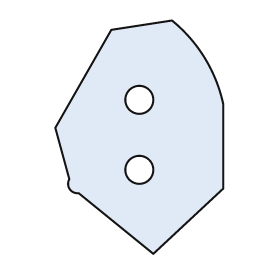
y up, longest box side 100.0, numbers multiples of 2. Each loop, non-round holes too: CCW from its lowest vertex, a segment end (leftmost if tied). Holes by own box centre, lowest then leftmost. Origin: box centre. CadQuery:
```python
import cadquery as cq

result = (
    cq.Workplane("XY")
    .moveTo(6.0, -50.0)
    .lineTo(36.0, -22.0)
    .lineTo(36.0, 14.0)
    .threePointArc((28.0, 34.0), (14.0, 50.0))
    .lineTo(-12.0, 46.0)
    .lineTo(-36.0, 4.0)
    .lineTo(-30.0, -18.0)
    .threePointArc((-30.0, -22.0), (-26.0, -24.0))
    .close()
    .moveTo(0.0, -14.0)
    .circle(6.0)
    .moveTo(0.0, 16.0)
    .circle(6.0)
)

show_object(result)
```